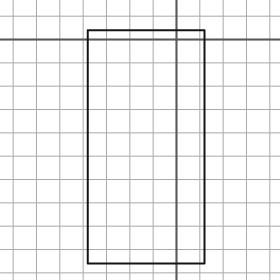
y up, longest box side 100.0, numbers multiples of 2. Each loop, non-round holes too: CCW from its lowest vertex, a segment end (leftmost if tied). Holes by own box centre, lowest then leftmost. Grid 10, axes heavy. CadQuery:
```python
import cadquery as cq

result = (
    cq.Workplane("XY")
    .moveTo(-38.0, -96.0)
    .lineTo(12.0, -96.0)
    .lineTo(12.0, 4.0)
    .lineTo(-38.0, 4.0)
    .close()
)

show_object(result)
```